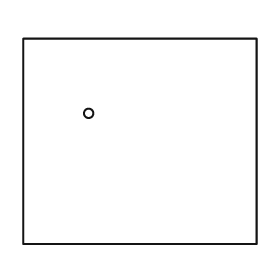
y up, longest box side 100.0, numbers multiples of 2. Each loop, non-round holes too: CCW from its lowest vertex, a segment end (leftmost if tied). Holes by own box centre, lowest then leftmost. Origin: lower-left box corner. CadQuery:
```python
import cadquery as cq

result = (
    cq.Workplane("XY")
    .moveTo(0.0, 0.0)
    .lineTo(100.0, 0.0)
    .lineTo(100.0, 88.0)
    .lineTo(0.0, 88.0)
    .close()
    .moveTo(28.0, 56.0)
    .circle(2.0)
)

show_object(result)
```